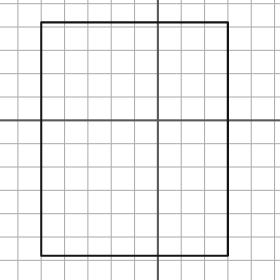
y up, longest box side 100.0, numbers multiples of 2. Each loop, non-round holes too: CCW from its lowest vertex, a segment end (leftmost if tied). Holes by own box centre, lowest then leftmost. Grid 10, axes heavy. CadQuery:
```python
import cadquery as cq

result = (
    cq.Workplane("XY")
    .moveTo(-50.0, -58.0)
    .lineTo(30.0, -58.0)
    .lineTo(30.0, 42.0)
    .lineTo(-50.0, 42.0)
    .close()
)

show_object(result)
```